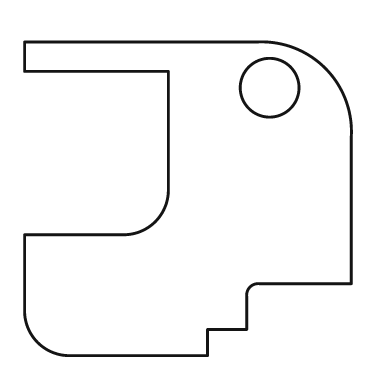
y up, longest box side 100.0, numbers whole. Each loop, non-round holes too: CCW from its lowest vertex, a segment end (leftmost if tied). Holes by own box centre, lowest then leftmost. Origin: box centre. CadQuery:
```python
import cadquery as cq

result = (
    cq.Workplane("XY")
    .moveTo(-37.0, -48.0)
    .lineTo(6.0, -48.0)
    .lineTo(6.0, -40.0)
    .lineTo(18.0, -40.0)
    .lineTo(18.0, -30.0)
    .threePointArc((19.0, -27.0), (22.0, -26.0))
    .lineTo(50.0, -26.0)
    .lineTo(50.0, 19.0)
    .threePointArc((42.0, 40.0), (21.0, 48.0))
    .lineTo(-50.0, 48.0)
    .lineTo(-50.0, 39.0)
    .lineTo(-6.0, 39.0)
    .lineTo(-6.0, 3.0)
    .threePointArc((-10.0, -7.0), (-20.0, -11.0))
    .lineTo(-50.0, -11.0)
    .lineTo(-50.0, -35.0)
    .threePointArc((-46.0, -44.0), (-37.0, -48.0))
    .close()
    .moveTo(25.0, 34.0)
    .circle(9.0)
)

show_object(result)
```